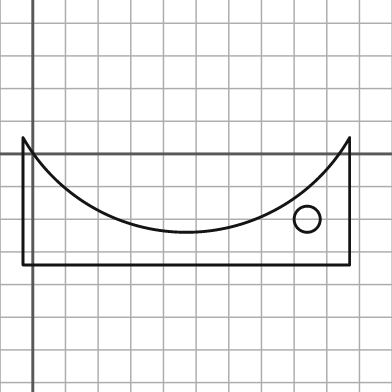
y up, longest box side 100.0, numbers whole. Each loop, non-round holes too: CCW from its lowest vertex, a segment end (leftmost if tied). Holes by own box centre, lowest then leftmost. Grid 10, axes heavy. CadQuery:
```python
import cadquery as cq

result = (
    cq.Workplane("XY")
    .moveTo(-3.0, -34.0)
    .lineTo(97.0, -34.0)
    .lineTo(97.0, 5.0)
    .threePointArc((47.0, -24.0), (-3.0, 5.0))
    .close()
    .moveTo(84.0, -20.0)
    .circle(4.0)
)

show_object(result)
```